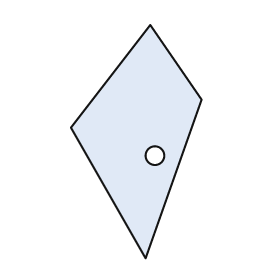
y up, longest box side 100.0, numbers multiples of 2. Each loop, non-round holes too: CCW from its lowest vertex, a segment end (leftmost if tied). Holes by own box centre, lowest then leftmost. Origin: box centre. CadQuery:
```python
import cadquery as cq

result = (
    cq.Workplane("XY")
    .moveTo(4.0, -50.0)
    .lineTo(28.0, 18.0)
    .lineTo(6.0, 50.0)
    .lineTo(-28.0, 6.0)
    .close()
    .moveTo(8.0, -6.0)
    .circle(4.0)
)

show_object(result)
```